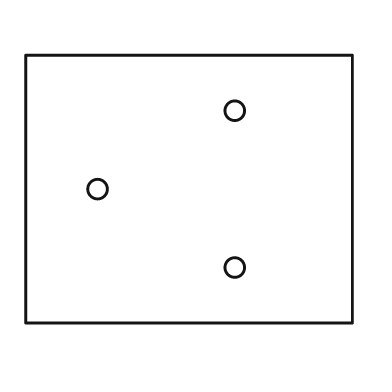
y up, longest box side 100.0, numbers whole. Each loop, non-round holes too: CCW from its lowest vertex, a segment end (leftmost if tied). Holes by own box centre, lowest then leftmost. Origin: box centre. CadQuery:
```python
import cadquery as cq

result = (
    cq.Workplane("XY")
    .moveTo(-50.0, -41.0)
    .lineTo(50.0, -41.0)
    .lineTo(50.0, 41.0)
    .lineTo(-50.0, 41.0)
    .close()
    .moveTo(14.0, -24.0)
    .circle(3.0)
    .moveTo(-28.0, 0.0)
    .circle(3.0)
    .moveTo(14.0, 24.0)
    .circle(3.0)
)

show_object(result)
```